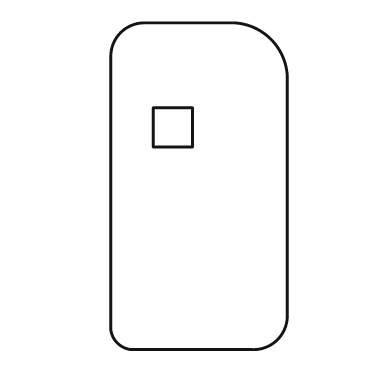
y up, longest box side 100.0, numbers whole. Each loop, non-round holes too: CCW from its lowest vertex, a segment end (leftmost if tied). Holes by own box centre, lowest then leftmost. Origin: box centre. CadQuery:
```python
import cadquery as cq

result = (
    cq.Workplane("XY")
    .moveTo(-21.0, -50.0)
    .lineTo(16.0, -50.0)
    .threePointArc((24.0, -47.0), (27.0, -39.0))
    .lineTo(27.0, 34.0)
    .threePointArc((22.0, 45.0), (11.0, 50.0))
    .lineTo(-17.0, 50.0)
    .threePointArc((-24.0, 47.0), (-27.0, 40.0))
    .lineTo(-27.0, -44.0)
    .threePointArc((-25.0, -48.0), (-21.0, -50.0))
    .close()
    .moveTo(-14.0, 12.0)
    .lineTo(-2.0, 12.0)
    .lineTo(-2.0, 24.0)
    .lineTo(-14.0, 24.0)
    .close()
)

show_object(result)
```